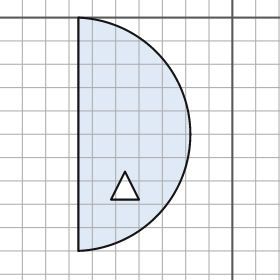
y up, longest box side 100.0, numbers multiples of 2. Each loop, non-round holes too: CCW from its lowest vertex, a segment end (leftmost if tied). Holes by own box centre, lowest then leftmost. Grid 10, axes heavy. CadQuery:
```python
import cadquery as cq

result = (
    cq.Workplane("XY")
    .moveTo(-66.0, -100.0)
    .threePointArc((-18.0, -50.0), (-66.0, 0.0))
    .close()
    .moveTo(-52.0, -78.0)
    .lineTo(-40.0, -78.0)
    .lineTo(-46.0, -66.0)
    .close()
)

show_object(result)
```